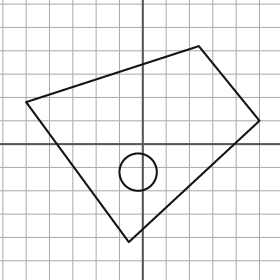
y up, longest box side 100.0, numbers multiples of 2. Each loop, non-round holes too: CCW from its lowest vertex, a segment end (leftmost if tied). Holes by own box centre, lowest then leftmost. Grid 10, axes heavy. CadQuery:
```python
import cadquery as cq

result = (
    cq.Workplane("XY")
    .moveTo(-6.0, -42.0)
    .lineTo(50.0, 10.0)
    .lineTo(24.0, 42.0)
    .lineTo(-50.0, 18.0)
    .close()
    .moveTo(-2.0, -12.0)
    .circle(8.0)
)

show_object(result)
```